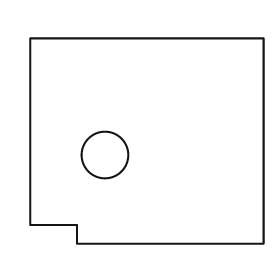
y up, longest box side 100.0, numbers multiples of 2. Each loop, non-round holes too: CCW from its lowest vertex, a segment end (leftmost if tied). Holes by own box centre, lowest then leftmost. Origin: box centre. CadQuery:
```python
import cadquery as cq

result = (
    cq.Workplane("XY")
    .moveTo(-30.0, -44.0)
    .lineTo(50.0, -44.0)
    .lineTo(50.0, 44.0)
    .lineTo(-50.0, 44.0)
    .lineTo(-50.0, -36.0)
    .lineTo(-30.0, -36.0)
    .close()
    .moveTo(-18.0, -6.0)
    .circle(10.0)
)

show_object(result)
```